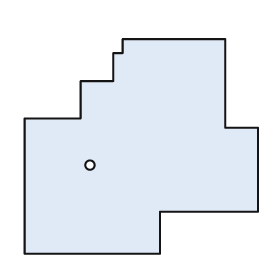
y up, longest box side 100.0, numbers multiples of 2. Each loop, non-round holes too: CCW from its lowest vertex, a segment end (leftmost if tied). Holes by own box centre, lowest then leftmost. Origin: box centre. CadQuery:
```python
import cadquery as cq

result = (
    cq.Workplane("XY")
    .moveTo(-50.0, -46.0)
    .lineTo(8.0, -46.0)
    .lineTo(8.0, -28.0)
    .lineTo(50.0, -28.0)
    .lineTo(50.0, 8.0)
    .lineTo(36.0, 8.0)
    .lineTo(36.0, 46.0)
    .lineTo(-8.0, 46.0)
    .lineTo(-8.0, 40.0)
    .lineTo(-12.0, 40.0)
    .lineTo(-12.0, 28.0)
    .lineTo(-26.0, 28.0)
    .lineTo(-26.0, 12.0)
    .lineTo(-50.0, 12.0)
    .close()
    .moveTo(-22.0, -8.0)
    .circle(2.0)
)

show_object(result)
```